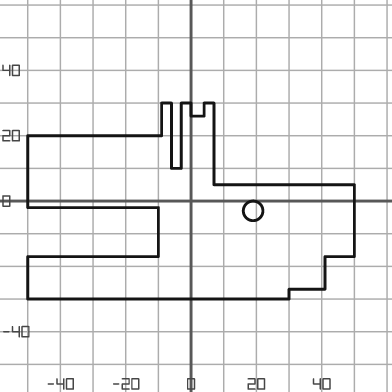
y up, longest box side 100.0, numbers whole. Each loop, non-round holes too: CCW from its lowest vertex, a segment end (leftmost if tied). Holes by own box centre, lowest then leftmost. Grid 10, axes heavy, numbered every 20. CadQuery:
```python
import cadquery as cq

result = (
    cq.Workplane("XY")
    .moveTo(-50.0, -30.0)
    .lineTo(30.0, -30.0)
    .lineTo(30.0, -27.0)
    .lineTo(41.0, -27.0)
    .lineTo(41.0, -17.0)
    .lineTo(50.0, -17.0)
    .lineTo(50.0, 5.0)
    .lineTo(7.0, 5.0)
    .lineTo(7.0, 30.0)
    .lineTo(4.0, 30.0)
    .lineTo(4.0, 26.0)
    .lineTo(0.0, 26.0)
    .lineTo(0.0, 30.0)
    .lineTo(-3.0, 30.0)
    .lineTo(-3.0, 10.0)
    .lineTo(-6.0, 10.0)
    .lineTo(-6.0, 30.0)
    .lineTo(-9.0, 30.0)
    .lineTo(-9.0, 20.0)
    .lineTo(-50.0, 20.0)
    .lineTo(-50.0, -2.0)
    .lineTo(-10.0, -2.0)
    .lineTo(-10.0, -17.0)
    .lineTo(-50.0, -17.0)
    .close()
    .moveTo(19.0, -3.0)
    .circle(3.0)
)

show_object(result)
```